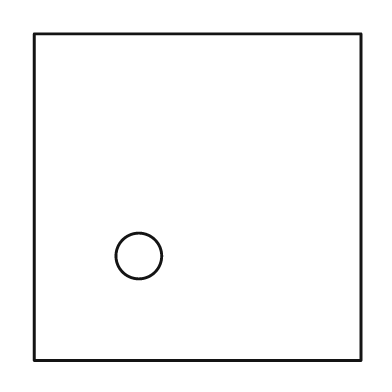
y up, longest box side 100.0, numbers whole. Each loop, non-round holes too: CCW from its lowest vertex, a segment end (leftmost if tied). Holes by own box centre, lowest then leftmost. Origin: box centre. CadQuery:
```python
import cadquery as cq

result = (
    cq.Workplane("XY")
    .moveTo(-50.0, -50.0)
    .lineTo(50.0, -50.0)
    .lineTo(50.0, 50.0)
    .lineTo(-50.0, 50.0)
    .close()
    .moveTo(-18.0, -18.0)
    .circle(7.0)
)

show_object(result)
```